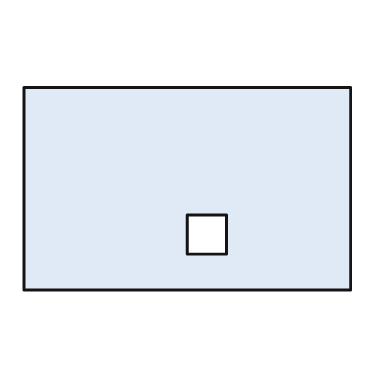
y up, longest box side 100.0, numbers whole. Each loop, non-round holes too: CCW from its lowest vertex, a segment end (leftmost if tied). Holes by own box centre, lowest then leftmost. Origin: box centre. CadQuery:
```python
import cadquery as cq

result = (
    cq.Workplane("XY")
    .moveTo(-50.0, -31.0)
    .lineTo(50.0, -31.0)
    .lineTo(50.0, 31.0)
    .lineTo(-50.0, 31.0)
    .close()
    .moveTo(0.0, -20.0)
    .lineTo(12.0, -20.0)
    .lineTo(12.0, -8.0)
    .lineTo(0.0, -8.0)
    .close()
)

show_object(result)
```